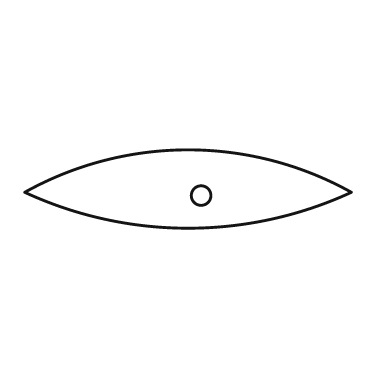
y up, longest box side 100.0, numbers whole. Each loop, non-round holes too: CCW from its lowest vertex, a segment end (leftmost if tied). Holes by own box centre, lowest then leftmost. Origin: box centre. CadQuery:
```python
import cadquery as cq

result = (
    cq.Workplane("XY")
    .moveTo(-50.0, -1.0)
    .threePointArc((0.0, -12.0), (50.0, -1.0))
    .threePointArc((0.0, 12.0), (-50.0, -1.0))
    .close()
    .moveTo(4.0, -2.0)
    .circle(3.0)
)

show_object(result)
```